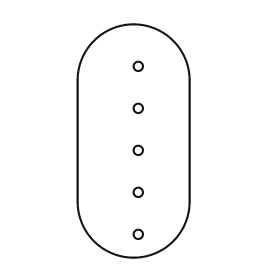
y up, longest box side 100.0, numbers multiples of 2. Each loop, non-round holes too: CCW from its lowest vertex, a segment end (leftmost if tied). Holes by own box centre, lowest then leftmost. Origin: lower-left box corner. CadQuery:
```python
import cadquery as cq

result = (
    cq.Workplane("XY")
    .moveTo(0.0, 24.0)
    .threePointArc((24.0, 0.0), (48.0, 24.0))
    .lineTo(48.0, 76.0)
    .threePointArc((24.0, 100.0), (0.0, 76.0))
    .close()
    .moveTo(26.0, 10.0)
    .circle(2.0)
    .moveTo(26.0, 28.0)
    .circle(2.0)
    .moveTo(26.0, 46.0)
    .circle(2.0)
    .moveTo(26.0, 64.0)
    .circle(2.0)
    .moveTo(26.0, 82.0)
    .circle(2.0)
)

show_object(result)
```